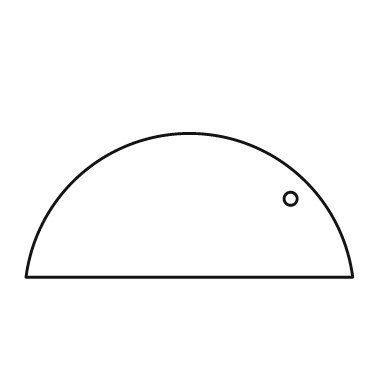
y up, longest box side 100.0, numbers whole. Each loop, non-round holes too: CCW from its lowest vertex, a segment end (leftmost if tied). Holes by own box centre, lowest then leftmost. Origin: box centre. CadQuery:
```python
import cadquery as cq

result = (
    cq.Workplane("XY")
    .moveTo(-50.0, -22.0)
    .lineTo(50.0, -22.0)
    .threePointArc((0.0, 22.0), (-50.0, -22.0))
    .close()
    .moveTo(31.0, 2.0)
    .circle(2.0)
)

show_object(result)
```